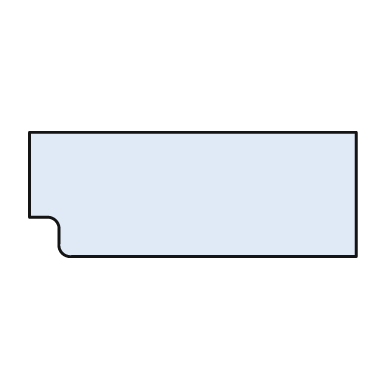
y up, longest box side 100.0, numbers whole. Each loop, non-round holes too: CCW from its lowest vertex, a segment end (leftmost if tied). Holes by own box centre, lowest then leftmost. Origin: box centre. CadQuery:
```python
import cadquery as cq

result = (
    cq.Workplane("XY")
    .moveTo(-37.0, -19.0)
    .lineTo(50.0, -19.0)
    .lineTo(50.0, 19.0)
    .lineTo(-50.0, 19.0)
    .lineTo(-50.0, -7.0)
    .lineTo(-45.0, -7.0)
    .threePointArc((-42.0, -8.0), (-41.0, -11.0))
    .lineTo(-41.0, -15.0)
    .threePointArc((-40.0, -18.0), (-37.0, -19.0))
    .close()
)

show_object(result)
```